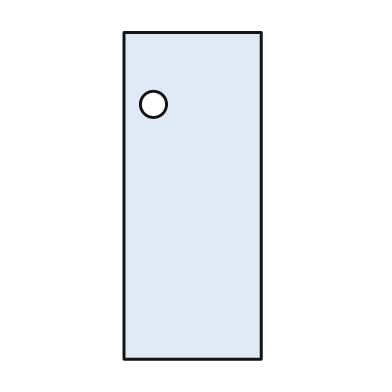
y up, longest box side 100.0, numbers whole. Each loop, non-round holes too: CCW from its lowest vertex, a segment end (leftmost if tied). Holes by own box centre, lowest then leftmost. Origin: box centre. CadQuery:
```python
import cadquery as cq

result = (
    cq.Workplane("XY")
    .moveTo(-21.0, -50.0)
    .lineTo(21.0, -50.0)
    .lineTo(21.0, 50.0)
    .lineTo(-21.0, 50.0)
    .close()
    .moveTo(-12.0, 28.0)
    .circle(4.0)
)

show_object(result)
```